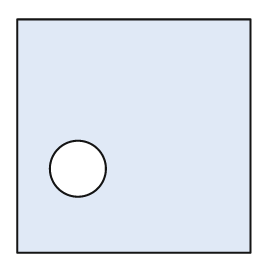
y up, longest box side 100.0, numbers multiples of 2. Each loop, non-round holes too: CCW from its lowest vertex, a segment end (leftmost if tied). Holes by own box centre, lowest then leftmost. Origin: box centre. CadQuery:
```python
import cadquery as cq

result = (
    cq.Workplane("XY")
    .moveTo(-50.0, -50.0)
    .lineTo(50.0, -50.0)
    .lineTo(50.0, 50.0)
    .lineTo(-50.0, 50.0)
    .close()
    .moveTo(-24.0, -14.0)
    .circle(12.0)
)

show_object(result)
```